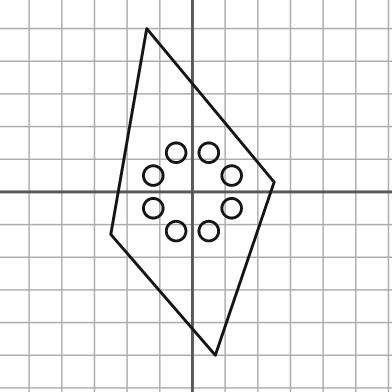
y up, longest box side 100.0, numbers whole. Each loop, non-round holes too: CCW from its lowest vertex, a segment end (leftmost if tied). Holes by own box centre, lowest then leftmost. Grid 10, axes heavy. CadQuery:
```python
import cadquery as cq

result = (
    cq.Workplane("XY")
    .moveTo(7.0, -50.0)
    .lineTo(25.0, 3.0)
    .lineTo(-14.0, 50.0)
    .lineTo(-25.0, -13.0)
    .close()
    .moveTo(-5.0, -12.0)
    .circle(3.0)
    .moveTo(5.0, -12.0)
    .circle(3.0)
    .moveTo(-12.0, -5.0)
    .circle(3.0)
    .moveTo(12.0, -5.0)
    .circle(3.0)
    .moveTo(-12.0, 5.0)
    .circle(3.0)
    .moveTo(12.0, 5.0)
    .circle(3.0)
    .moveTo(-5.0, 12.0)
    .circle(3.0)
    .moveTo(5.0, 12.0)
    .circle(3.0)
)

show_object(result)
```